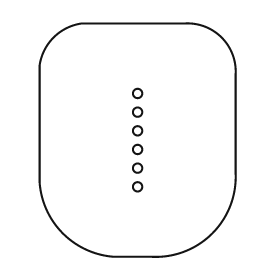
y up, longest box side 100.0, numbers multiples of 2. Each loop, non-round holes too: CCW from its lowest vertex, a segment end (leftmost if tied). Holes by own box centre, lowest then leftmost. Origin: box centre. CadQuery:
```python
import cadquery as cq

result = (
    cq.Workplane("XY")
    .moveTo(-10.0, -50.0)
    .lineTo(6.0, -50.0)
    .threePointArc((32.0, -40.0), (42.0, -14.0))
    .lineTo(42.0, 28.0)
    .threePointArc((36.0, 44.0), (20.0, 50.0))
    .lineTo(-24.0, 50.0)
    .threePointArc((-36.0, 44.0), (-42.0, 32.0))
    .lineTo(-42.0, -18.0)
    .threePointArc((-32.0, -40.0), (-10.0, -50.0))
    .close()
    .moveTo(0.0, -20.0)
    .circle(2.0)
    .moveTo(0.0, -12.0)
    .circle(2.0)
    .moveTo(0.0, -4.0)
    .circle(2.0)
    .moveTo(0.0, 4.0)
    .circle(2.0)
    .moveTo(0.0, 12.0)
    .circle(2.0)
    .moveTo(0.0, 20.0)
    .circle(2.0)
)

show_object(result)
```